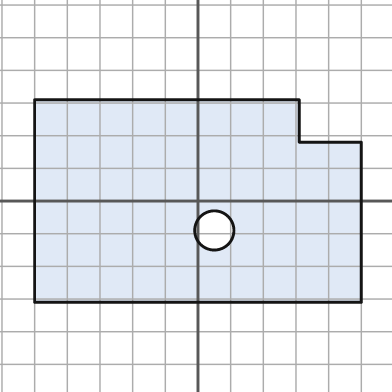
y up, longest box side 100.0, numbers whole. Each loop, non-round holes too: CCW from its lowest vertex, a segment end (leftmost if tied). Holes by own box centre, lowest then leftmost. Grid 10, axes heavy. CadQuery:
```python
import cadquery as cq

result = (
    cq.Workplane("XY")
    .moveTo(-50.0, -31.0)
    .lineTo(50.0, -31.0)
    .lineTo(50.0, 18.0)
    .lineTo(31.0, 18.0)
    .lineTo(31.0, 31.0)
    .lineTo(-50.0, 31.0)
    .close()
    .moveTo(5.0, -9.0)
    .circle(6.0)
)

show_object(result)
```